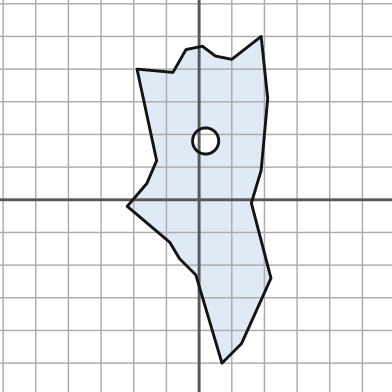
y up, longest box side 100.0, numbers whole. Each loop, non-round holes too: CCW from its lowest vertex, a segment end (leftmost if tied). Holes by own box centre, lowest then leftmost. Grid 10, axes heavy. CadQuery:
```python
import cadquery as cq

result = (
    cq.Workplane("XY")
    .moveTo(7.0, -50.0)
    .lineTo(13.0, -44.0)
    .lineTo(22.0, -24.0)
    .lineTo(16.0, -1.0)
    .lineTo(19.0, 9.0)
    .lineTo(21.0, 31.0)
    .lineTo(19.0, 50.0)
    .lineTo(10.0, 43.0)
    .lineTo(5.0, 44.0)
    .lineTo(1.0, 47.0)
    .lineTo(-4.0, 46.0)
    .lineTo(-8.0, 39.0)
    .lineTo(-19.0, 40.0)
    .lineTo(-13.0, 12.0)
    .lineTo(-16.0, 5.0)
    .lineTo(-22.0, -2.0)
    .lineTo(-9.0, -13.0)
    .lineTo(-6.0, -18.0)
    .lineTo(-1.0, -23.0)
    .close()
    .moveTo(2.0, 18.0)
    .circle(4.0)
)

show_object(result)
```